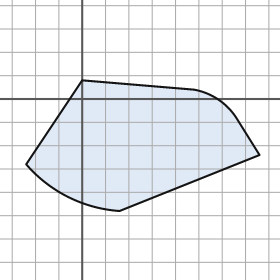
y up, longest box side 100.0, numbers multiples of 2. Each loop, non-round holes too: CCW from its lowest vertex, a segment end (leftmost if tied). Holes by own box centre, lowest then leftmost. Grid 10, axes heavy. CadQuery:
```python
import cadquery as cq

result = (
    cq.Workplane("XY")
    .moveTo(16.0, -48.0)
    .lineTo(76.0, -24.0)
    .lineTo(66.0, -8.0)
    .threePointArc((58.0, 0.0), (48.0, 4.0))
    .lineTo(0.0, 8.0)
    .lineTo(-24.0, -28.0)
    .threePointArc((-6.0, -42.0), (16.0, -48.0))
    .close()
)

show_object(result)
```